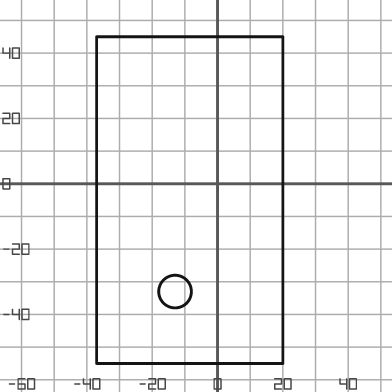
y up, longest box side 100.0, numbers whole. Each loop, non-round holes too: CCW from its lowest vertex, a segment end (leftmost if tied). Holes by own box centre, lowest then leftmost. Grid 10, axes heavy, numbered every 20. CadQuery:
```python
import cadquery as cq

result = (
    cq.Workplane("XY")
    .moveTo(-37.0, -55.0)
    .lineTo(20.0, -55.0)
    .lineTo(20.0, 45.0)
    .lineTo(-37.0, 45.0)
    .close()
    .moveTo(-13.0, -33.0)
    .circle(5.0)
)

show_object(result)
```